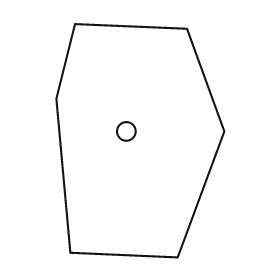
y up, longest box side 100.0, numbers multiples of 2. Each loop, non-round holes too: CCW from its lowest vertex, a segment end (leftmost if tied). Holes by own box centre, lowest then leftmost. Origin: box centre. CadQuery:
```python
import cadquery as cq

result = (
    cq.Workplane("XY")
    .moveTo(16.0, -50.0)
    .lineTo(36.0, 4.0)
    .lineTo(20.0, 48.0)
    .lineTo(-28.0, 50.0)
    .lineTo(-36.0, 18.0)
    .lineTo(-30.0, -48.0)
    .close()
    .moveTo(-6.0, 4.0)
    .circle(4.0)
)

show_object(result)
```